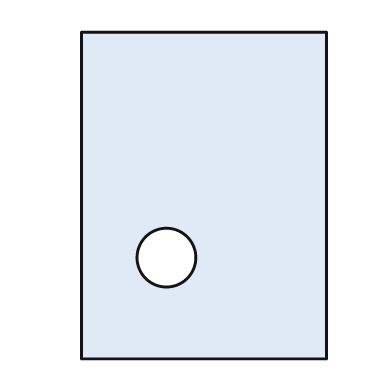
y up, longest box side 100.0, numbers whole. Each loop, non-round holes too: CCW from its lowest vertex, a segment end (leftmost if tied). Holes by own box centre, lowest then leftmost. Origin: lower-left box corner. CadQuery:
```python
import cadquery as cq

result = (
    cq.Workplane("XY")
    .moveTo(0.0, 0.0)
    .lineTo(75.0, 0.0)
    .lineTo(75.0, 100.0)
    .lineTo(0.0, 100.0)
    .close()
    .moveTo(26.0, 31.0)
    .circle(9.0)
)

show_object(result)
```